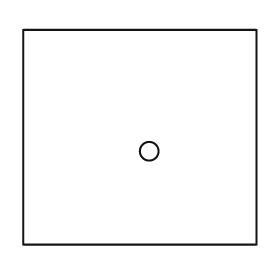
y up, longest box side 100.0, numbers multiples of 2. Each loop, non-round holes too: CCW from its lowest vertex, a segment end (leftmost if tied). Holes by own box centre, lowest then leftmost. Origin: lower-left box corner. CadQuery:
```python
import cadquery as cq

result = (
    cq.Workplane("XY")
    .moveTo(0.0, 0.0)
    .lineTo(100.0, 0.0)
    .lineTo(100.0, 92.0)
    .lineTo(0.0, 92.0)
    .close()
    .moveTo(54.0, 40.0)
    .circle(4.0)
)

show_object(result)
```